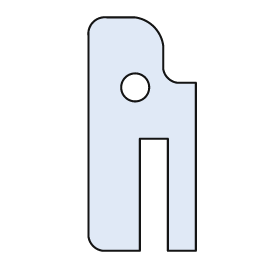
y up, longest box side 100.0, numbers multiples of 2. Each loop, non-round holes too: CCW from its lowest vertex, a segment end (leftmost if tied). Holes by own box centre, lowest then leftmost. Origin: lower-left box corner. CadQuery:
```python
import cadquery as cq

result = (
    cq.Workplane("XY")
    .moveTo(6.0, 0.0)
    .lineTo(22.0, 0.0)
    .lineTo(22.0, 48.0)
    .lineTo(34.0, 48.0)
    .lineTo(34.0, 0.0)
    .lineTo(46.0, 0.0)
    .lineTo(46.0, 72.0)
    .lineTo(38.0, 72.0)
    .threePointArc((34.0, 74.0), (32.0, 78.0))
    .lineTo(32.0, 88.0)
    .threePointArc((28.0, 96.0), (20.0, 100.0))
    .lineTo(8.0, 100.0)
    .threePointArc((2.0, 98.0), (0.0, 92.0))
    .lineTo(0.0, 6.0)
    .threePointArc((2.0, 2.0), (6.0, 0.0))
    .close()
    .moveTo(20.0, 70.0)
    .circle(6.0)
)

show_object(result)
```